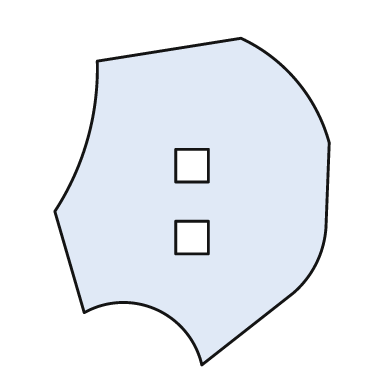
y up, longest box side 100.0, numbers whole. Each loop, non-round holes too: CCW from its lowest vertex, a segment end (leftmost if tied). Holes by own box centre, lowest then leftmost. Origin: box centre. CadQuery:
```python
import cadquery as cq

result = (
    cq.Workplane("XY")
    .moveTo(3.0, -50.0)
    .lineTo(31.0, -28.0)
    .threePointArc((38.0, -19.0), (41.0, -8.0))
    .lineTo(42.0, 18.0)
    .threePointArc((32.0, 37.0), (15.0, 50.0))
    .lineTo(-29.0, 43.0)
    .threePointArc((-32.0, 19.0), (-42.0, -3.0))
    .lineTo(-33.0, -34.0)
    .threePointArc((-11.0, -33.0), (3.0, -50.0))
    .close()
    .moveTo(-5.0, -16.0)
    .lineTo(5.0, -16.0)
    .lineTo(5.0, -6.0)
    .lineTo(-5.0, -6.0)
    .close()
    .moveTo(-5.0, 6.0)
    .lineTo(5.0, 6.0)
    .lineTo(5.0, 16.0)
    .lineTo(-5.0, 16.0)
    .close()
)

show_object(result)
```